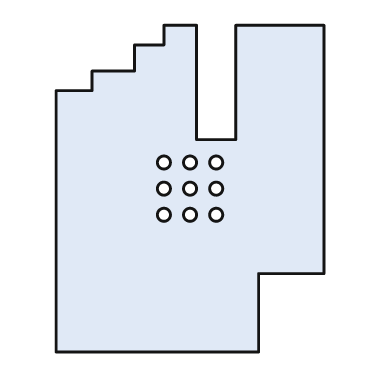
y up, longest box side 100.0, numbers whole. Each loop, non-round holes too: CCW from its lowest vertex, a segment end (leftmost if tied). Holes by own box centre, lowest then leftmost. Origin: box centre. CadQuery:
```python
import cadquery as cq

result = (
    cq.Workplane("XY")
    .moveTo(-41.0, -50.0)
    .lineTo(21.0, -50.0)
    .lineTo(21.0, -26.0)
    .lineTo(41.0, -26.0)
    .lineTo(41.0, 50.0)
    .lineTo(14.0, 50.0)
    .lineTo(14.0, 15.0)
    .lineTo(2.0, 15.0)
    .lineTo(2.0, 50.0)
    .lineTo(-8.0, 50.0)
    .lineTo(-8.0, 44.0)
    .lineTo(-17.0, 44.0)
    .lineTo(-17.0, 36.0)
    .lineTo(-30.0, 36.0)
    .lineTo(-30.0, 30.0)
    .lineTo(-41.0, 30.0)
    .close()
    .moveTo(-8.0, -8.0)
    .circle(2.0)
    .moveTo(0.0, -8.0)
    .circle(2.0)
    .moveTo(8.0, -8.0)
    .circle(2.0)
    .moveTo(-8.0, 0.0)
    .circle(2.0)
    .moveTo(0.0, 0.0)
    .circle(2.0)
    .moveTo(8.0, 0.0)
    .circle(2.0)
    .moveTo(-8.0, 8.0)
    .circle(2.0)
    .moveTo(0.0, 8.0)
    .circle(2.0)
    .moveTo(8.0, 8.0)
    .circle(2.0)
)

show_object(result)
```